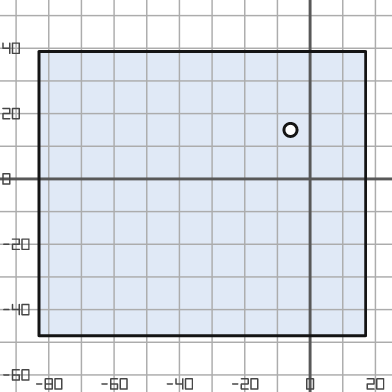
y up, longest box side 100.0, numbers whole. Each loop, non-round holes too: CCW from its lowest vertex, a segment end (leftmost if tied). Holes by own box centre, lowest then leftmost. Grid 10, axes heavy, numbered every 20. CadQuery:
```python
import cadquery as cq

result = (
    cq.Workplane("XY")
    .moveTo(-83.0, -48.0)
    .lineTo(17.0, -48.0)
    .lineTo(17.0, 39.0)
    .lineTo(-83.0, 39.0)
    .close()
    .moveTo(-6.0, 15.0)
    .circle(2.0)
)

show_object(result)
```